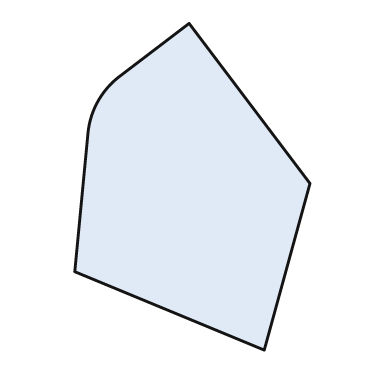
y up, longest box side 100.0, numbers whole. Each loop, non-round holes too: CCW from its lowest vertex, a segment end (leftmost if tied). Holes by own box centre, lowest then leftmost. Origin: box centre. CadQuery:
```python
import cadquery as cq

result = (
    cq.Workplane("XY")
    .moveTo(22.0, -50.0)
    .lineTo(36.0, 1.0)
    .lineTo(-1.0, 50.0)
    .lineTo(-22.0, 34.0)
    .threePointArc((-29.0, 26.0), (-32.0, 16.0))
    .lineTo(-36.0, -26.0)
    .close()
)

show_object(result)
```